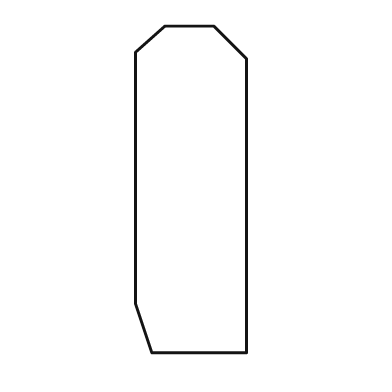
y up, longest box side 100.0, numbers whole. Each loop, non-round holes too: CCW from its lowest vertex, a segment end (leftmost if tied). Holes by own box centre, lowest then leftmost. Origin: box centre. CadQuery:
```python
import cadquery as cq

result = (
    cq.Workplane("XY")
    .moveTo(-12.0, -50.0)
    .lineTo(17.0, -50.0)
    .lineTo(17.0, 40.0)
    .lineTo(7.0, 50.0)
    .lineTo(-8.0, 50.0)
    .lineTo(-17.0, 42.0)
    .lineTo(-17.0, -35.0)
    .close()
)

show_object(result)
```